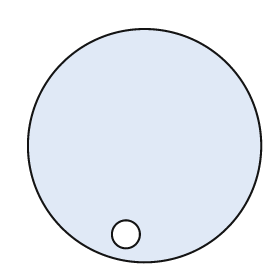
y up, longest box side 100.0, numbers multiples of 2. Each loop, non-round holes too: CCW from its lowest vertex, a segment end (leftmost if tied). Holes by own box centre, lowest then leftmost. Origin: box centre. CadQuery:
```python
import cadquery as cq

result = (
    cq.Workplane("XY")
    .moveTo(0.0, 0.0)
    .circle(50.0)
    .moveTo(-8.0, -38.0)
    .circle(6.0)
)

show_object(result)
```